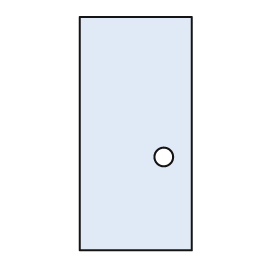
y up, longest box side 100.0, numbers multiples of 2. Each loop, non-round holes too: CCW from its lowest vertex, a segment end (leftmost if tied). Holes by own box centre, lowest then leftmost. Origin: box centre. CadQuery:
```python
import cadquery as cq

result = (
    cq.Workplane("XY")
    .moveTo(-24.0, -50.0)
    .lineTo(24.0, -50.0)
    .lineTo(24.0, 50.0)
    .lineTo(-24.0, 50.0)
    .close()
    .moveTo(12.0, -10.0)
    .circle(4.0)
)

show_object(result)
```